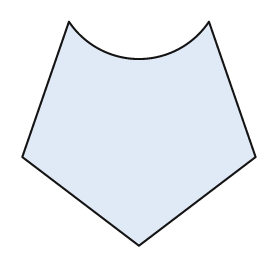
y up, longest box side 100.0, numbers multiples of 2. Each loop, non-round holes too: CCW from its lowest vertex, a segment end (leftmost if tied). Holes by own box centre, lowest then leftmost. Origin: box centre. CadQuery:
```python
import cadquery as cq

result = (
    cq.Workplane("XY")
    .moveTo(0.0, -48.0)
    .lineTo(50.0, -10.0)
    .lineTo(30.0, 48.0)
    .threePointArc((0.0, 32.0), (-30.0, 48.0))
    .lineTo(-50.0, -10.0)
    .close()
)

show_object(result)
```